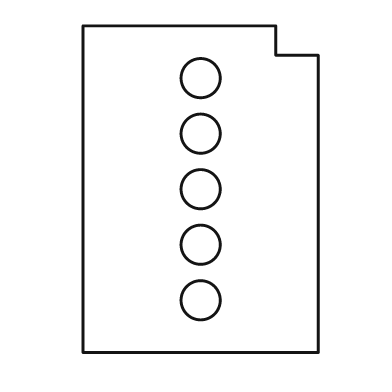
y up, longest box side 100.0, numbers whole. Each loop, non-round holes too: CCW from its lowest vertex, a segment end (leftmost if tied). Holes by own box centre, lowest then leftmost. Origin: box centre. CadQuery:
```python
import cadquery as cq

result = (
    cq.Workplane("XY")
    .moveTo(-36.0, -50.0)
    .lineTo(36.0, -50.0)
    .lineTo(36.0, 41.0)
    .lineTo(23.0, 41.0)
    .lineTo(23.0, 50.0)
    .lineTo(-36.0, 50.0)
    .close()
    .moveTo(0.0, -34.0)
    .circle(6.0)
    .moveTo(0.0, -17.0)
    .circle(6.0)
    .moveTo(0.0, 0.0)
    .circle(6.0)
    .moveTo(0.0, 17.0)
    .circle(6.0)
    .moveTo(0.0, 34.0)
    .circle(6.0)
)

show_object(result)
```